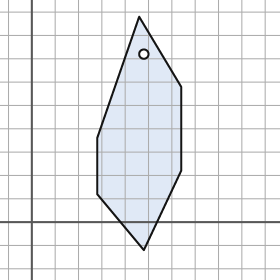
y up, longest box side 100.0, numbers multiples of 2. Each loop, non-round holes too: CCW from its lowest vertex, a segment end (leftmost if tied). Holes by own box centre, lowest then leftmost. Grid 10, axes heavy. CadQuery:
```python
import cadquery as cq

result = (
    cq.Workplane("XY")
    .moveTo(48.0, -12.0)
    .lineTo(64.0, 22.0)
    .lineTo(64.0, 58.0)
    .lineTo(46.0, 88.0)
    .lineTo(28.0, 36.0)
    .lineTo(28.0, 12.0)
    .close()
    .moveTo(48.0, 72.0)
    .circle(2.0)
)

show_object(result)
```